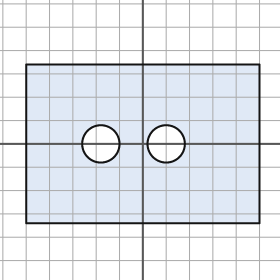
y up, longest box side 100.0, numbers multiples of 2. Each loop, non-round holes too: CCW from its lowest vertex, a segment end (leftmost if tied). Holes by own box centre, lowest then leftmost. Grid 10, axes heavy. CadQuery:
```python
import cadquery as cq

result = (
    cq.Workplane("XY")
    .moveTo(-50.0, -34.0)
    .lineTo(50.0, -34.0)
    .lineTo(50.0, 34.0)
    .lineTo(-50.0, 34.0)
    .close()
    .moveTo(-18.0, 0.0)
    .circle(8.0)
    .moveTo(10.0, 0.0)
    .circle(8.0)
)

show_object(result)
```